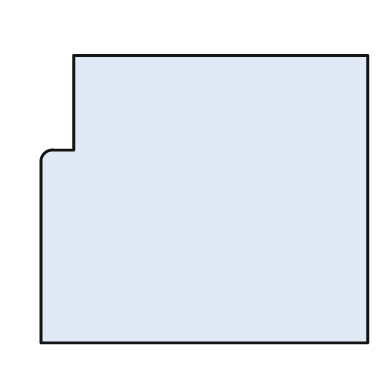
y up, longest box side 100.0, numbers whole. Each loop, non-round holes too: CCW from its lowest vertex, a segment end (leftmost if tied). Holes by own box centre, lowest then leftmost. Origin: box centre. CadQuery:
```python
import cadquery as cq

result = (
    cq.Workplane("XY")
    .moveTo(-50.0, -44.0)
    .lineTo(50.0, -44.0)
    .lineTo(50.0, 44.0)
    .lineTo(-40.0, 44.0)
    .lineTo(-40.0, 15.0)
    .lineTo(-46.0, 15.0)
    .threePointArc((-49.0, 14.0), (-50.0, 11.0))
    .close()
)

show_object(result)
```